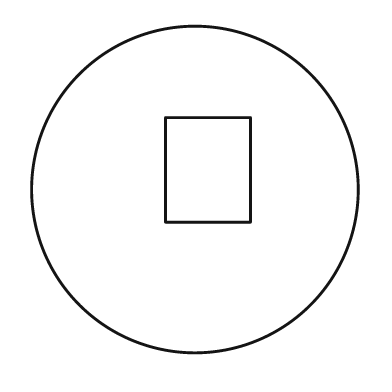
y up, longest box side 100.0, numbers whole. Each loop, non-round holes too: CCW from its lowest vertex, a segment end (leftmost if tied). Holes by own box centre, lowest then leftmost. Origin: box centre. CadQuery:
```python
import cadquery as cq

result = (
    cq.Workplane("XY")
    .moveTo(0.0, 0.0)
    .circle(50.0)
    .moveTo(-9.0, -10.0)
    .lineTo(17.0, -10.0)
    .lineTo(17.0, 22.0)
    .lineTo(-9.0, 22.0)
    .close()
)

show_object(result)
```